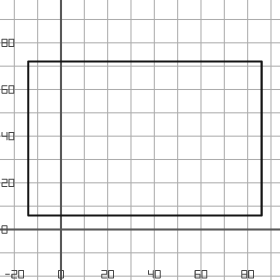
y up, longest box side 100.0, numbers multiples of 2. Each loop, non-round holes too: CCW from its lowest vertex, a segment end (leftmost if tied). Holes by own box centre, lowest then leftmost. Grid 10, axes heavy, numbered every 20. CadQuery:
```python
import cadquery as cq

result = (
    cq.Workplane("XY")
    .moveTo(-14.0, 6.0)
    .lineTo(86.0, 6.0)
    .lineTo(86.0, 72.0)
    .lineTo(-14.0, 72.0)
    .close()
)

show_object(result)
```